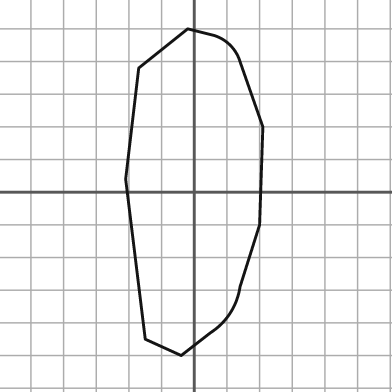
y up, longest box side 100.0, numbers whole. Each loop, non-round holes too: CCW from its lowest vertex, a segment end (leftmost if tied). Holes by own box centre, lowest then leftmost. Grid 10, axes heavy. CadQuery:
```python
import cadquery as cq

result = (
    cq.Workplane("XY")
    .moveTo(-4.0, -50.0)
    .lineTo(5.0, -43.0)
    .threePointArc((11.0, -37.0), (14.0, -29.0))
    .lineTo(20.0, -10.0)
    .lineTo(21.0, 20.0)
    .lineTo(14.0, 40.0)
    .threePointArc((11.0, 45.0), (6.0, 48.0))
    .lineTo(-2.0, 50.0)
    .lineTo(-17.0, 38.0)
    .lineTo(-21.0, 4.0)
    .lineTo(-15.0, -45.0)
    .close()
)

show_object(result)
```